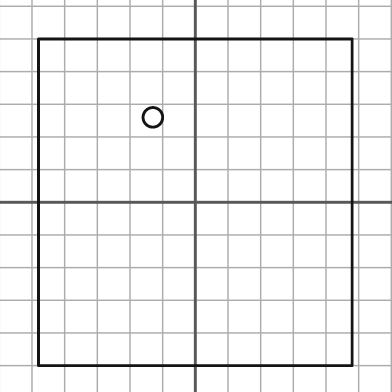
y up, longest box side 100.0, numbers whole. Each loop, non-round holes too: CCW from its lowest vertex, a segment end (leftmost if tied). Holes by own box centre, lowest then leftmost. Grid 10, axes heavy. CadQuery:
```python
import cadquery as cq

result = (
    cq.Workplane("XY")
    .moveTo(-48.0, -50.0)
    .lineTo(48.0, -50.0)
    .lineTo(48.0, 50.0)
    .lineTo(-48.0, 50.0)
    .close()
    .moveTo(-13.0, 26.0)
    .circle(3.0)
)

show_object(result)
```